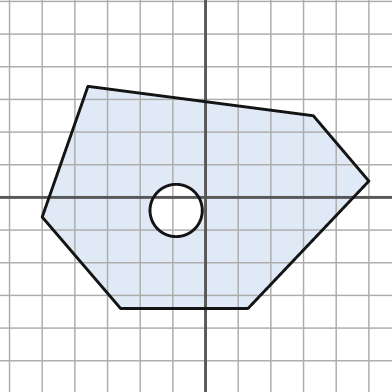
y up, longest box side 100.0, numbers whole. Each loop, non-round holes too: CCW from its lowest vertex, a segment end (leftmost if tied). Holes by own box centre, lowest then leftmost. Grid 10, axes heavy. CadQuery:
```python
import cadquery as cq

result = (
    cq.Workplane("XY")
    .moveTo(-26.0, -34.0)
    .lineTo(13.0, -34.0)
    .lineTo(50.0, 5.0)
    .lineTo(33.0, 25.0)
    .lineTo(-36.0, 34.0)
    .lineTo(-50.0, -6.0)
    .close()
    .moveTo(-9.0, -4.0)
    .circle(8.0)
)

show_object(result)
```